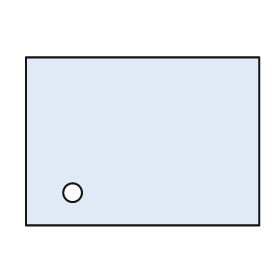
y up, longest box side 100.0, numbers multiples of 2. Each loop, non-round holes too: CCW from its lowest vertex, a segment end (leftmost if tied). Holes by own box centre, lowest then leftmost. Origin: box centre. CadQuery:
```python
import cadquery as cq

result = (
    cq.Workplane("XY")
    .moveTo(-50.0, -36.0)
    .lineTo(50.0, -36.0)
    .lineTo(50.0, 36.0)
    .lineTo(-50.0, 36.0)
    .close()
    .moveTo(-30.0, -22.0)
    .circle(4.0)
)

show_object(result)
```